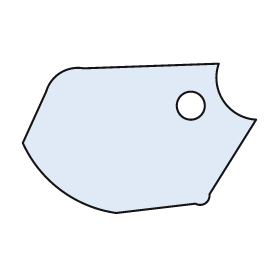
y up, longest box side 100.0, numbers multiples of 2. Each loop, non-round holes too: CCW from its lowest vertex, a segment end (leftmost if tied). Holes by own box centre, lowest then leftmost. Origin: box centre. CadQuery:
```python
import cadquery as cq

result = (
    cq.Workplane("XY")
    .moveTo(-10.0, -32.0)
    .lineTo(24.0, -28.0)
    .threePointArc((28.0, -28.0), (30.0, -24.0))
    .lineTo(50.0, 8.0)
    .threePointArc((36.0, 16.0), (34.0, 32.0))
    .lineTo(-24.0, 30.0)
    .threePointArc((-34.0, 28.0), (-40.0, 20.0))
    .lineTo(-50.0, -2.0)
    .threePointArc((-34.0, -22.0), (-10.0, -32.0))
    .close()
    .moveTo(22.0, 14.0)
    .circle(6.0)
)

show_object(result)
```